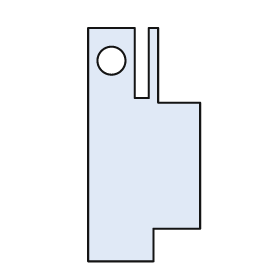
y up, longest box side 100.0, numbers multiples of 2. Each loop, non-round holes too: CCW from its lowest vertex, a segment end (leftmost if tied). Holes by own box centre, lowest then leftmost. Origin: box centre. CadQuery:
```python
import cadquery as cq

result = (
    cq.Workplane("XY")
    .moveTo(-24.0, -50.0)
    .lineTo(4.0, -50.0)
    .lineTo(4.0, -36.0)
    .lineTo(24.0, -36.0)
    .lineTo(24.0, 18.0)
    .lineTo(6.0, 18.0)
    .lineTo(6.0, 50.0)
    .lineTo(2.0, 50.0)
    .lineTo(2.0, 20.0)
    .lineTo(-4.0, 20.0)
    .lineTo(-4.0, 50.0)
    .lineTo(-24.0, 50.0)
    .close()
    .moveTo(-14.0, 36.0)
    .circle(6.0)
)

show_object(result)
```